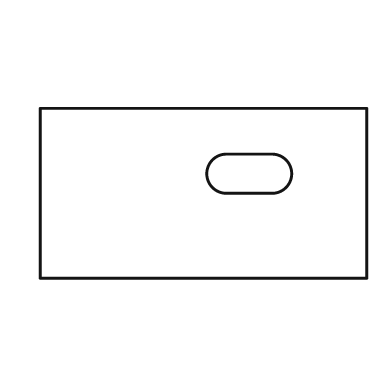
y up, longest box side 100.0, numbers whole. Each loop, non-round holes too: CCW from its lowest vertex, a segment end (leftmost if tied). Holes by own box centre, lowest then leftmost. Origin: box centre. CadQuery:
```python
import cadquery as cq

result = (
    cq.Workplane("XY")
    .moveTo(-50.0, -26.0)
    .lineTo(50.0, -26.0)
    .lineTo(50.0, 26.0)
    .lineTo(-50.0, 26.0)
    .close()
    .moveTo(7.0, 0.0)
    .lineTo(21.0, 0.0)
    .threePointArc((27.0, 6.0), (21.0, 12.0))
    .lineTo(7.0, 12.0)
    .threePointArc((1.0, 6.0), (7.0, 0.0))
    .close()
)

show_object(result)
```